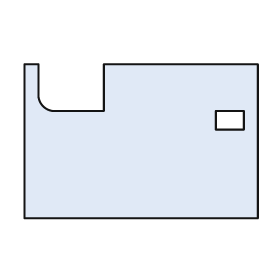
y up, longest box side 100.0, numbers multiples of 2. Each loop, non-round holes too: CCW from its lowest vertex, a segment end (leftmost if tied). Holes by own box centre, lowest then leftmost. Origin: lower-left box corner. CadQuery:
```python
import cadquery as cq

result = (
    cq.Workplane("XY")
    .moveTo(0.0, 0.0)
    .lineTo(100.0, 0.0)
    .lineTo(100.0, 66.0)
    .lineTo(34.0, 66.0)
    .lineTo(34.0, 46.0)
    .lineTo(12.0, 46.0)
    .threePointArc((8.0, 48.0), (6.0, 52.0))
    .lineTo(6.0, 66.0)
    .lineTo(0.0, 66.0)
    .close()
    .moveTo(82.0, 38.0)
    .lineTo(94.0, 38.0)
    .lineTo(94.0, 46.0)
    .lineTo(82.0, 46.0)
    .close()
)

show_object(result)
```